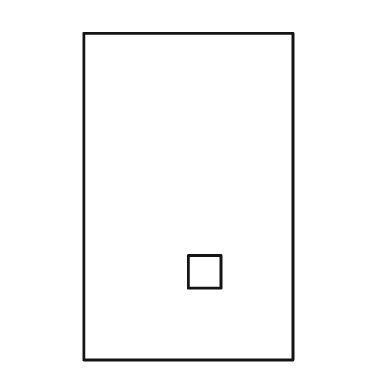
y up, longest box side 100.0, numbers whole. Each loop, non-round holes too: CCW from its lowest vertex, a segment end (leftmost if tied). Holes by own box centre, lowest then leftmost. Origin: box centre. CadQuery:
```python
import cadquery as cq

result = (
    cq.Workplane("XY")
    .moveTo(-32.0, -50.0)
    .lineTo(32.0, -50.0)
    .lineTo(32.0, 50.0)
    .lineTo(-32.0, 50.0)
    .close()
    .moveTo(0.0, -28.0)
    .lineTo(10.0, -28.0)
    .lineTo(10.0, -18.0)
    .lineTo(0.0, -18.0)
    .close()
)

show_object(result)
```